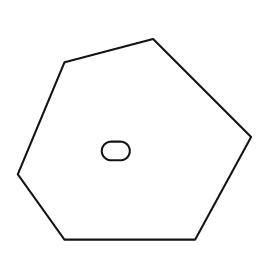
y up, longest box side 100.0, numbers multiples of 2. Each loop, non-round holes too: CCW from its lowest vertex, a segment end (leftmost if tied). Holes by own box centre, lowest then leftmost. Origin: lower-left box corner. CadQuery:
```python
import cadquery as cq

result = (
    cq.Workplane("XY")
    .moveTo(20.0, 0.0)
    .lineTo(76.0, 0.0)
    .lineTo(100.0, 44.0)
    .lineTo(58.0, 86.0)
    .lineTo(20.0, 76.0)
    .lineTo(0.0, 28.0)
    .close()
    .moveTo(40.0, 34.0)
    .lineTo(44.0, 34.0)
    .threePointArc((48.0, 38.0), (44.0, 42.0))
    .lineTo(40.0, 42.0)
    .threePointArc((36.0, 38.0), (40.0, 34.0))
    .close()
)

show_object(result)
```